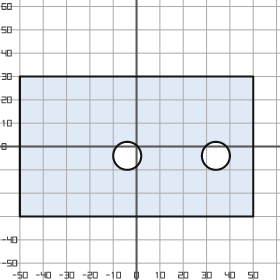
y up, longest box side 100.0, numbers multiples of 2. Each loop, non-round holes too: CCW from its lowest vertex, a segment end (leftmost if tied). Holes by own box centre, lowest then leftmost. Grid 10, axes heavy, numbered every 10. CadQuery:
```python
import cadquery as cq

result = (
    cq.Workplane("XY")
    .moveTo(-50.0, -30.0)
    .lineTo(50.0, -30.0)
    .lineTo(50.0, 30.0)
    .lineTo(-50.0, 30.0)
    .close()
    .moveTo(-4.0, -4.0)
    .circle(6.0)
    .moveTo(34.0, -4.0)
    .circle(6.0)
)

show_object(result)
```